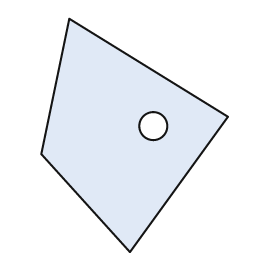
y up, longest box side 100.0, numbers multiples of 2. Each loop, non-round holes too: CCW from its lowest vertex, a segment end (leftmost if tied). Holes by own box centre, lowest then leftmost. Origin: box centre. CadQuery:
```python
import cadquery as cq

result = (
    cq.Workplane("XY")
    .moveTo(-2.0, -50.0)
    .lineTo(40.0, 8.0)
    .lineTo(-28.0, 50.0)
    .lineTo(-40.0, -8.0)
    .close()
    .moveTo(8.0, 4.0)
    .circle(6.0)
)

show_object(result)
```